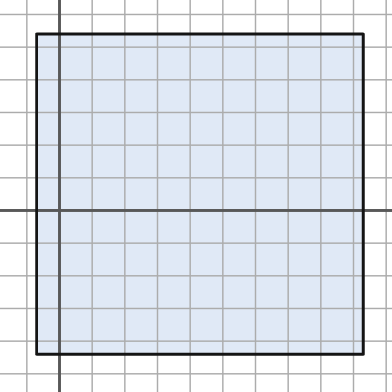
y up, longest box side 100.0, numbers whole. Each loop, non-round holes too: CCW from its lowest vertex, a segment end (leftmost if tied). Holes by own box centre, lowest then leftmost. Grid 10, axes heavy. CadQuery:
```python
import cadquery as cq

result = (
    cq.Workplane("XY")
    .moveTo(-7.0, -44.0)
    .lineTo(93.0, -44.0)
    .lineTo(93.0, 54.0)
    .lineTo(-7.0, 54.0)
    .close()
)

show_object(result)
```